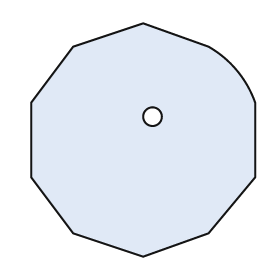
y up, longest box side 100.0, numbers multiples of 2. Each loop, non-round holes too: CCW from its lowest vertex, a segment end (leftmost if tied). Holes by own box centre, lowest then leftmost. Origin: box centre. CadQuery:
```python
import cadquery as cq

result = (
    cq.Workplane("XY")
    .moveTo(0.0, -50.0)
    .lineTo(28.0, -40.0)
    .lineTo(48.0, -16.0)
    .lineTo(48.0, 16.0)
    .threePointArc((40.0, 30.0), (28.0, 40.0))
    .lineTo(0.0, 50.0)
    .lineTo(-30.0, 40.0)
    .lineTo(-48.0, 16.0)
    .lineTo(-48.0, -16.0)
    .lineTo(-30.0, -40.0)
    .close()
    .moveTo(4.0, 10.0)
    .circle(4.0)
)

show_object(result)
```